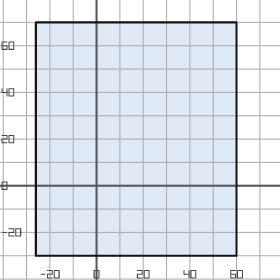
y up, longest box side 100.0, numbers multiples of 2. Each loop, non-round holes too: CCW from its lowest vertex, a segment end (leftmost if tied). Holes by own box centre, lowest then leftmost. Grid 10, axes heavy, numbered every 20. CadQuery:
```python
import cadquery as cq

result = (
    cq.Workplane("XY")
    .moveTo(-26.0, -30.0)
    .lineTo(60.0, -30.0)
    .lineTo(60.0, 70.0)
    .lineTo(-26.0, 70.0)
    .close()
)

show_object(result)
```